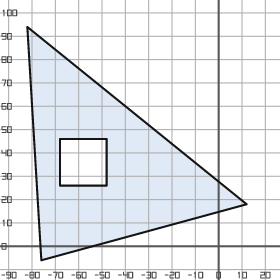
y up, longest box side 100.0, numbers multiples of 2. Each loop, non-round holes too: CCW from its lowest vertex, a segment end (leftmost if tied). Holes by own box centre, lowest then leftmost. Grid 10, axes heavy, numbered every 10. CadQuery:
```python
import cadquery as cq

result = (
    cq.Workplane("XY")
    .moveTo(-76.0, -6.0)
    .lineTo(12.0, 18.0)
    .lineTo(-82.0, 94.0)
    .close()
    .moveTo(-68.0, 26.0)
    .lineTo(-48.0, 26.0)
    .lineTo(-48.0, 46.0)
    .lineTo(-68.0, 46.0)
    .close()
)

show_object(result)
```